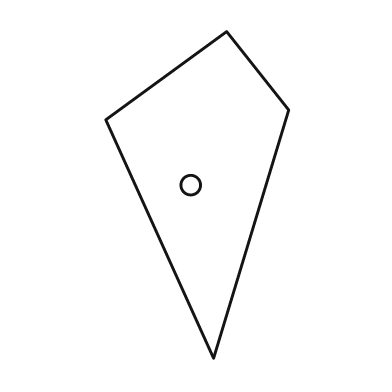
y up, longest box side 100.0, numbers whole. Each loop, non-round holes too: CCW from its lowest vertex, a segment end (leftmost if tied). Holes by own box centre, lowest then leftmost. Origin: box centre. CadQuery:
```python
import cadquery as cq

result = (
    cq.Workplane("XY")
    .moveTo(5.0, -50.0)
    .lineTo(28.0, 26.0)
    .lineTo(9.0, 50.0)
    .lineTo(-28.0, 23.0)
    .close()
    .moveTo(-2.0, 3.0)
    .circle(3.0)
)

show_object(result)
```